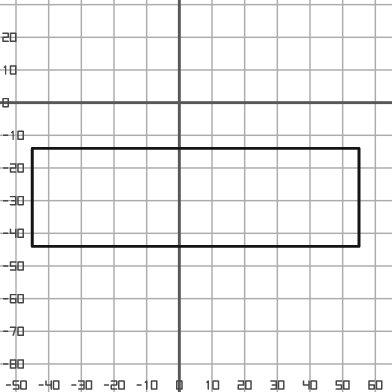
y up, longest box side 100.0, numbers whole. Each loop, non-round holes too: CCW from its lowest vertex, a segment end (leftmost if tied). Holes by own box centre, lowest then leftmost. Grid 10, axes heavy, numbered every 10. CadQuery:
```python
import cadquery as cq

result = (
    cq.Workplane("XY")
    .moveTo(-45.0, -44.0)
    .lineTo(55.0, -44.0)
    .lineTo(55.0, -14.0)
    .lineTo(-45.0, -14.0)
    .close()
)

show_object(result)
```